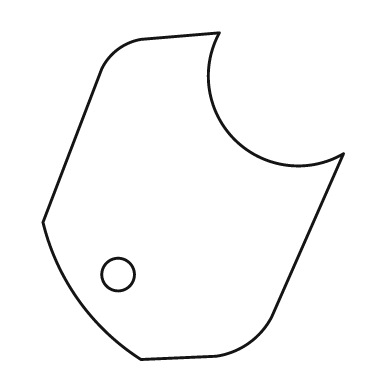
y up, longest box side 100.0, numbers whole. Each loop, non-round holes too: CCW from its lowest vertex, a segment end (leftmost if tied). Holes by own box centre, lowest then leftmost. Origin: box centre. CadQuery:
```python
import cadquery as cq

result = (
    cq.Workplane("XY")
    .moveTo(-16.0, -50.0)
    .lineTo(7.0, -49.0)
    .threePointArc((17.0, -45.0), (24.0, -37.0))
    .lineTo(46.0, 13.0)
    .threePointArc((13.0, 17.0), (8.0, 50.0))
    .lineTo(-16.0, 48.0)
    .threePointArc((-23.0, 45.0), (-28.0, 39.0))
    .lineTo(-46.0, -8.0)
    .threePointArc((-35.0, -32.0), (-16.0, -50.0))
    .close()
    .moveTo(-23.0, -24.0)
    .circle(5.0)
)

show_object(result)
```